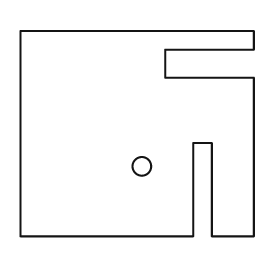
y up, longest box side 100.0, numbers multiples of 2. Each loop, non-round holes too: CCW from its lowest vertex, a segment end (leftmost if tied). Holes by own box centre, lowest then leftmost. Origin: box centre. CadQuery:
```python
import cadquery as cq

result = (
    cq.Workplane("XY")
    .moveTo(-50.0, -44.0)
    .lineTo(24.0, -44.0)
    .lineTo(24.0, -4.0)
    .lineTo(32.0, -4.0)
    .lineTo(32.0, -44.0)
    .lineTo(50.0, -44.0)
    .lineTo(50.0, 24.0)
    .lineTo(12.0, 24.0)
    .lineTo(12.0, 36.0)
    .lineTo(50.0, 36.0)
    .lineTo(50.0, 44.0)
    .lineTo(-50.0, 44.0)
    .close()
    .moveTo(2.0, -14.0)
    .circle(4.0)
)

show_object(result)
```